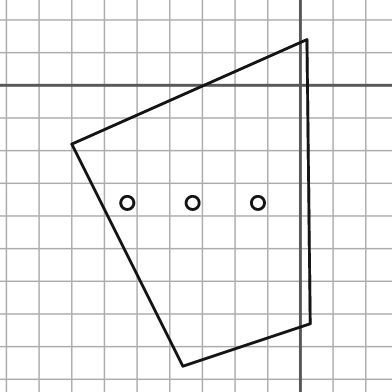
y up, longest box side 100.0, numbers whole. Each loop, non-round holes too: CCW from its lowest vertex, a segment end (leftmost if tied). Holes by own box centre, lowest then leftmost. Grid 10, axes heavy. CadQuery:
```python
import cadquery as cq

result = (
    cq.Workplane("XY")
    .moveTo(-36.0, -86.0)
    .lineTo(3.0, -73.0)
    .lineTo(2.0, 14.0)
    .lineTo(-70.0, -18.0)
    .close()
    .moveTo(-53.0, -36.0)
    .circle(2.0)
    .moveTo(-33.0, -36.0)
    .circle(2.0)
    .moveTo(-13.0, -36.0)
    .circle(2.0)
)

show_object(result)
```